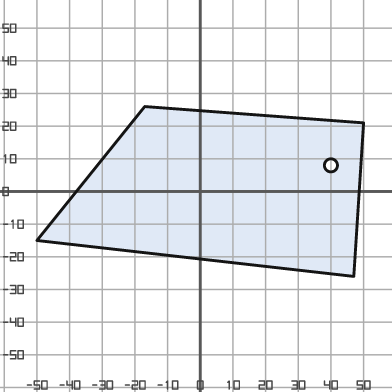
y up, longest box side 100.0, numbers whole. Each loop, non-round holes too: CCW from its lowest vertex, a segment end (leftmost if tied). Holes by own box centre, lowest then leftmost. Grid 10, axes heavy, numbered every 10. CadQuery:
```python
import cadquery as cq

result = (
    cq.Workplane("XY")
    .moveTo(47.0, -26.0)
    .lineTo(50.0, 21.0)
    .lineTo(-17.0, 26.0)
    .lineTo(-50.0, -15.0)
    .close()
    .moveTo(40.0, 8.0)
    .circle(2.0)
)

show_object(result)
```